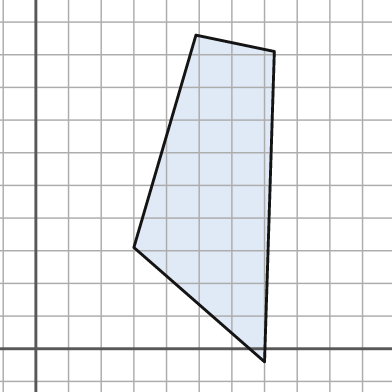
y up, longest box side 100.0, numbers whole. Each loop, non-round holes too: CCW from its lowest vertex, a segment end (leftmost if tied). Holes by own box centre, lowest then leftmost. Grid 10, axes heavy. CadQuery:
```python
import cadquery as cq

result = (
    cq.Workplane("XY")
    .moveTo(70.0, -4.0)
    .lineTo(73.0, 91.0)
    .lineTo(49.0, 96.0)
    .lineTo(30.0, 31.0)
    .close()
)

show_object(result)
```